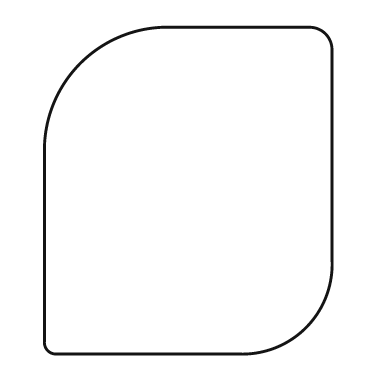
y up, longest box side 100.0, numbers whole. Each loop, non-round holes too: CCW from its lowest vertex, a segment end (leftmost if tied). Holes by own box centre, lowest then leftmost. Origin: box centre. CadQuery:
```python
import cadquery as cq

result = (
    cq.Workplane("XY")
    .moveTo(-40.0, -50.0)
    .lineTo(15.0, -50.0)
    .threePointArc((36.0, -42.0), (44.0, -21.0))
    .lineTo(44.0, 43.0)
    .threePointArc((42.0, 48.0), (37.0, 50.0))
    .lineTo(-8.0, 50.0)
    .threePointArc((-33.0, 39.0), (-44.0, 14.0))
    .lineTo(-44.0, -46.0)
    .threePointArc((-43.0, -49.0), (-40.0, -50.0))
    .close()
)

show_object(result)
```